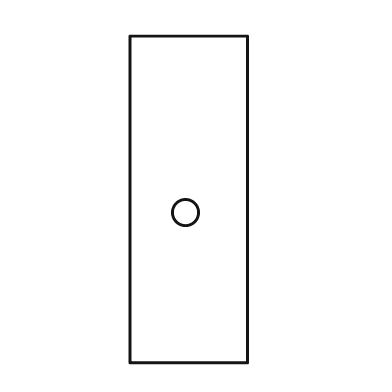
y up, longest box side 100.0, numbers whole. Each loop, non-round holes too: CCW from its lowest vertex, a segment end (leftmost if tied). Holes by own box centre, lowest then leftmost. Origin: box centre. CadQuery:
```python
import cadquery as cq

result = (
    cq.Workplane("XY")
    .moveTo(-18.0, -50.0)
    .lineTo(18.0, -50.0)
    .lineTo(18.0, 50.0)
    .lineTo(-18.0, 50.0)
    .close()
    .moveTo(-1.0, -4.0)
    .circle(4.0)
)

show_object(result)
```